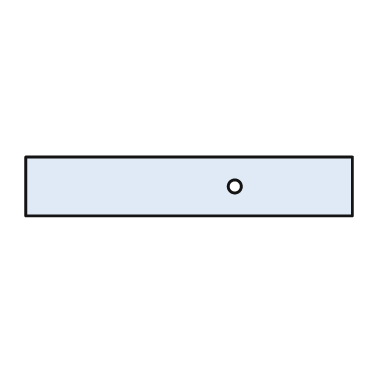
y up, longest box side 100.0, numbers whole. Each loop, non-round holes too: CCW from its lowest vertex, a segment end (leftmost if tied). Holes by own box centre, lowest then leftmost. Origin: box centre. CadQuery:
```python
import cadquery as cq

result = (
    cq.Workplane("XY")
    .moveTo(-50.0, -9.0)
    .lineTo(50.0, -9.0)
    .lineTo(50.0, 9.0)
    .lineTo(-50.0, 9.0)
    .close()
    .moveTo(14.0, 0.0)
    .circle(2.0)
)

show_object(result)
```